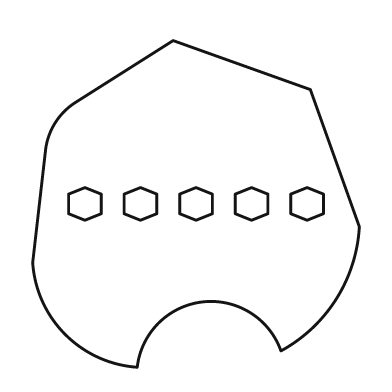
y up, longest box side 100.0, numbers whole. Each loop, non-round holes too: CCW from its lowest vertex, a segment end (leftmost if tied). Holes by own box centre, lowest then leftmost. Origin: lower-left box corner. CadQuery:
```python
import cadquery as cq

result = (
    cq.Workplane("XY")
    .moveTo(32.0, 0.0)
    .threePointArc((52.0, 20.0), (76.0, 5.0))
    .threePointArc((93.0, 21.0), (100.0, 43.0))
    .lineTo(85.0, 85.0)
    .lineTo(43.0, 100.0)
    .lineTo(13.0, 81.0)
    .threePointArc((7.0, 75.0), (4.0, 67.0))
    .lineTo(0.0, 32.0)
    .threePointArc((10.0, 10.0), (32.0, 0.0))
    .close()
    .moveTo(16.0, 45.0)
    .lineTo(21.0, 47.0)
    .lineTo(21.0, 53.0)
    .lineTo(16.0, 55.0)
    .lineTo(11.0, 53.0)
    .lineTo(11.0, 47.0)
    .close()
    .moveTo(33.0, 45.0)
    .lineTo(38.0, 47.0)
    .lineTo(38.0, 53.0)
    .lineTo(33.0, 55.0)
    .lineTo(28.0, 53.0)
    .lineTo(28.0, 47.0)
    .close()
    .moveTo(50.0, 45.0)
    .lineTo(55.0, 47.0)
    .lineTo(55.0, 53.0)
    .lineTo(50.0, 55.0)
    .lineTo(45.0, 53.0)
    .lineTo(45.0, 47.0)
    .close()
    .moveTo(67.0, 45.0)
    .lineTo(72.0, 47.0)
    .lineTo(72.0, 53.0)
    .lineTo(67.0, 55.0)
    .lineTo(62.0, 53.0)
    .lineTo(62.0, 47.0)
    .close()
    .moveTo(84.0, 45.0)
    .lineTo(89.0, 47.0)
    .lineTo(89.0, 53.0)
    .lineTo(84.0, 55.0)
    .lineTo(79.0, 53.0)
    .lineTo(79.0, 47.0)
    .close()
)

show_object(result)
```